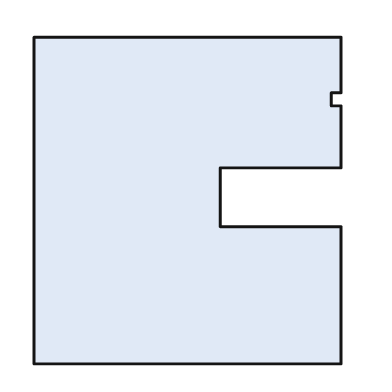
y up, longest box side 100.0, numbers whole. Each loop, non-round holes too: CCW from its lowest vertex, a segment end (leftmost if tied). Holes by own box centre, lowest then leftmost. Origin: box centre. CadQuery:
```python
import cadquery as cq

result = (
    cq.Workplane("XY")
    .moveTo(-47.0, -50.0)
    .lineTo(47.0, -50.0)
    .lineTo(47.0, -8.0)
    .lineTo(10.0, -8.0)
    .lineTo(10.0, 10.0)
    .lineTo(47.0, 10.0)
    .lineTo(47.0, 29.0)
    .lineTo(44.0, 29.0)
    .lineTo(44.0, 33.0)
    .lineTo(47.0, 33.0)
    .lineTo(47.0, 50.0)
    .lineTo(-47.0, 50.0)
    .close()
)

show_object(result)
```